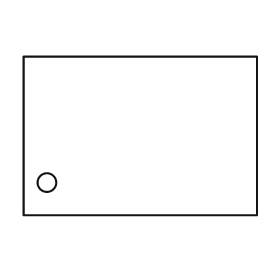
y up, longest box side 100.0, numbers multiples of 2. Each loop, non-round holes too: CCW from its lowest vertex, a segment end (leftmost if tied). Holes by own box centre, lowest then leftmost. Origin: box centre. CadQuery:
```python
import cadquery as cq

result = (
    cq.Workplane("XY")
    .moveTo(-50.0, -34.0)
    .lineTo(50.0, -34.0)
    .lineTo(50.0, 34.0)
    .lineTo(-50.0, 34.0)
    .close()
    .moveTo(-40.0, -20.0)
    .circle(4.0)
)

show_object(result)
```